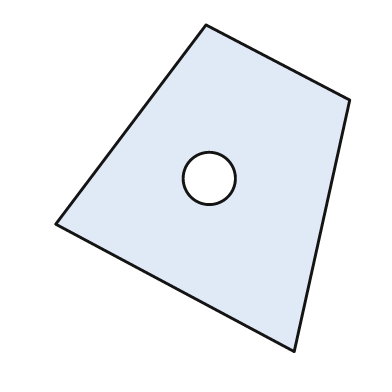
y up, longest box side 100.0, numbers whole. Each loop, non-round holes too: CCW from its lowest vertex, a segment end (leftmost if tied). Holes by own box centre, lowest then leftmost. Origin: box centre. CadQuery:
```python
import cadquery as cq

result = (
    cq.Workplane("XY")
    .moveTo(28.0, -50.0)
    .lineTo(45.0, 27.0)
    .lineTo(1.0, 50.0)
    .lineTo(-45.0, -11.0)
    .close()
    .moveTo(2.0, 3.0)
    .circle(8.0)
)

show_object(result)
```